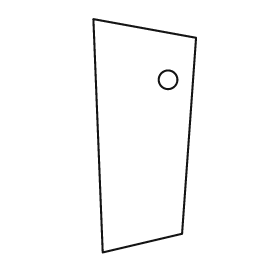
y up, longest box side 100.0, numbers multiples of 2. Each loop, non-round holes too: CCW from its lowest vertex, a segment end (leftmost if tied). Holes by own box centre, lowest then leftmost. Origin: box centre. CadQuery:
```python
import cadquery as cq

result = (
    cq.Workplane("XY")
    .moveTo(-18.0, -50.0)
    .lineTo(16.0, -42.0)
    .lineTo(22.0, 42.0)
    .lineTo(-22.0, 50.0)
    .close()
    .moveTo(10.0, 24.0)
    .circle(4.0)
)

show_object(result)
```